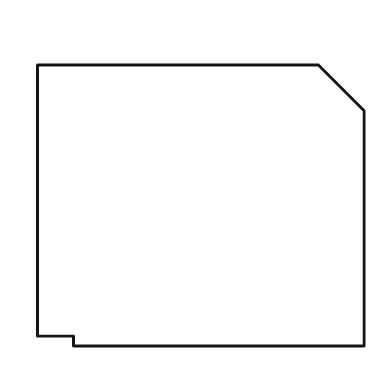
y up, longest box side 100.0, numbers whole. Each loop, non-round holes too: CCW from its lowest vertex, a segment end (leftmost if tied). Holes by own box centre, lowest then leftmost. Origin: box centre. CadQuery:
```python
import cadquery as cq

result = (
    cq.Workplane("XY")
    .moveTo(-39.0, -43.0)
    .lineTo(50.0, -43.0)
    .lineTo(50.0, 29.0)
    .lineTo(36.0, 43.0)
    .lineTo(-50.0, 43.0)
    .lineTo(-50.0, -40.0)
    .lineTo(-39.0, -40.0)
    .close()
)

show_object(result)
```